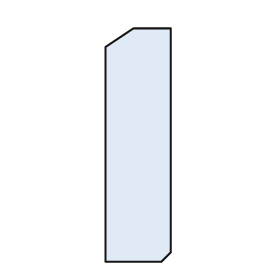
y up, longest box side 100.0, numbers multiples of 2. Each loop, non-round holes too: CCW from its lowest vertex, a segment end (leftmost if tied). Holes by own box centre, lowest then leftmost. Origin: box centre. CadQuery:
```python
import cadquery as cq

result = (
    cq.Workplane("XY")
    .moveTo(-14.0, -50.0)
    .lineTo(10.0, -50.0)
    .lineTo(14.0, -46.0)
    .lineTo(14.0, 50.0)
    .lineTo(-2.0, 50.0)
    .lineTo(-14.0, 42.0)
    .close()
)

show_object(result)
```